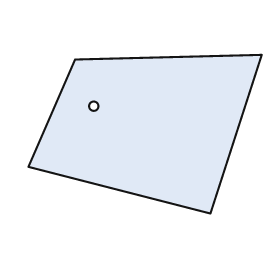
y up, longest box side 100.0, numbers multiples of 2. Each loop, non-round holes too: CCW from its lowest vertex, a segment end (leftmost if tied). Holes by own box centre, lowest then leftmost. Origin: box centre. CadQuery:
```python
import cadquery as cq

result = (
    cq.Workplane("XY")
    .moveTo(28.0, -34.0)
    .lineTo(50.0, 34.0)
    .lineTo(-30.0, 32.0)
    .lineTo(-50.0, -14.0)
    .close()
    .moveTo(-22.0, 12.0)
    .circle(2.0)
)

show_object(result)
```